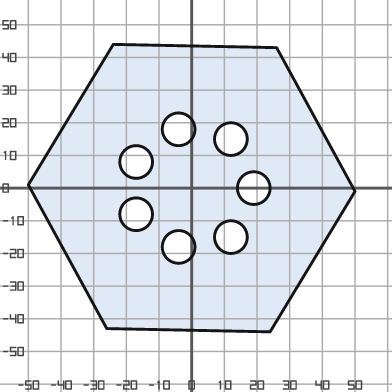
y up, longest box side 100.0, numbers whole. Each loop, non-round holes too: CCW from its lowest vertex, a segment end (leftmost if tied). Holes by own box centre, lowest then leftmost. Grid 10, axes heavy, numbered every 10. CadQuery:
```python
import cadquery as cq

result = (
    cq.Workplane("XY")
    .moveTo(24.0, -44.0)
    .lineTo(50.0, -1.0)
    .lineTo(26.0, 43.0)
    .lineTo(-24.0, 44.0)
    .lineTo(-50.0, 1.0)
    .lineTo(-26.0, -43.0)
    .close()
    .moveTo(-4.0, -18.0)
    .circle(5.0)
    .moveTo(12.0, -15.0)
    .circle(5.0)
    .moveTo(-17.0, -8.0)
    .circle(5.0)
    .moveTo(19.0, 0.0)
    .circle(5.0)
    .moveTo(-17.0, 8.0)
    .circle(5.0)
    .moveTo(12.0, 15.0)
    .circle(5.0)
    .moveTo(-4.0, 18.0)
    .circle(5.0)
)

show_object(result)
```